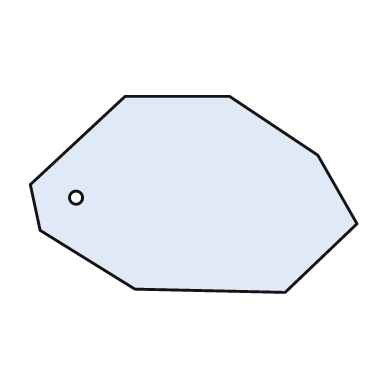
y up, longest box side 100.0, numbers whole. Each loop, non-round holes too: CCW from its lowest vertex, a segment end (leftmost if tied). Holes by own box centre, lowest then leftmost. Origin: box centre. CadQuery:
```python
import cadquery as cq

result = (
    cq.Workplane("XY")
    .moveTo(28.0, -30.0)
    .lineTo(50.0, -9.0)
    .lineTo(38.0, 12.0)
    .lineTo(11.0, 30.0)
    .lineTo(-21.0, 30.0)
    .lineTo(-50.0, 3.0)
    .lineTo(-47.0, -11.0)
    .lineTo(-18.0, -29.0)
    .close()
    .moveTo(-36.0, -1.0)
    .circle(2.0)
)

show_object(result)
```